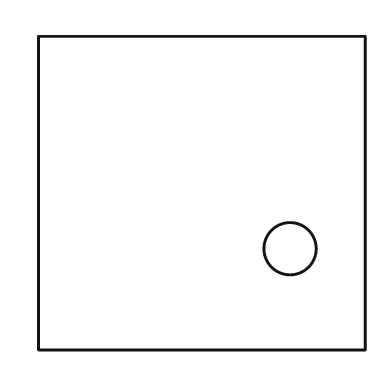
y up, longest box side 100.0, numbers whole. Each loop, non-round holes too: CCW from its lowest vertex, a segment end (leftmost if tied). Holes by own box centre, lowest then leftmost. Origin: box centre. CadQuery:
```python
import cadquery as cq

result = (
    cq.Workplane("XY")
    .moveTo(-50.0, -48.0)
    .lineTo(50.0, -48.0)
    .lineTo(50.0, 48.0)
    .lineTo(-50.0, 48.0)
    .close()
    .moveTo(27.0, -17.0)
    .circle(8.0)
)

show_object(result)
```